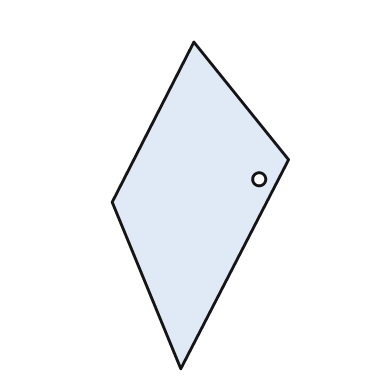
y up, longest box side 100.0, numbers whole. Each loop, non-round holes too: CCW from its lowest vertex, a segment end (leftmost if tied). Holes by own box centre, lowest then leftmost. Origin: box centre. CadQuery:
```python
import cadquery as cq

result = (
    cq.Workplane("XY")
    .moveTo(-6.0, -50.0)
    .lineTo(27.0, 14.0)
    .lineTo(-2.0, 50.0)
    .lineTo(-27.0, 1.0)
    .close()
    .moveTo(18.0, 8.0)
    .circle(2.0)
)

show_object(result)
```